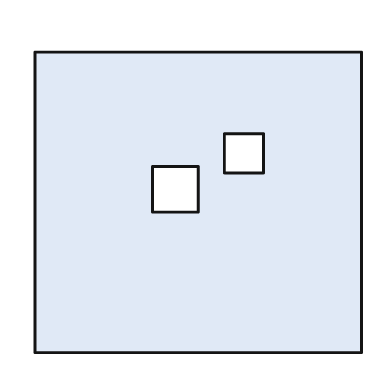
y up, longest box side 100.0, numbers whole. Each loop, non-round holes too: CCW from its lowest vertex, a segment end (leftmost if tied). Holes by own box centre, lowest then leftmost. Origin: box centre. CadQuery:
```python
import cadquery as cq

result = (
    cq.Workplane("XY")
    .moveTo(-50.0, -46.0)
    .lineTo(50.0, -46.0)
    .lineTo(50.0, 46.0)
    .lineTo(-50.0, 46.0)
    .close()
    .moveTo(-14.0, -3.0)
    .lineTo(0.0, -3.0)
    .lineTo(0.0, 11.0)
    .lineTo(-14.0, 11.0)
    .close()
    .moveTo(8.0, 9.0)
    .lineTo(20.0, 9.0)
    .lineTo(20.0, 21.0)
    .lineTo(8.0, 21.0)
    .close()
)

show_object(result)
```